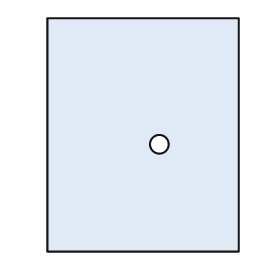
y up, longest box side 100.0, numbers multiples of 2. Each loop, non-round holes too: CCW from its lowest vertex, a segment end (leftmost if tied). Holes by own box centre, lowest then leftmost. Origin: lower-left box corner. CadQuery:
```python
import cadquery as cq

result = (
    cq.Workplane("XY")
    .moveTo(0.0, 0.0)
    .lineTo(82.0, 0.0)
    .lineTo(82.0, 100.0)
    .lineTo(0.0, 100.0)
    .close()
    .moveTo(48.0, 46.0)
    .circle(4.0)
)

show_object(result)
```